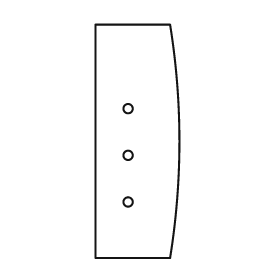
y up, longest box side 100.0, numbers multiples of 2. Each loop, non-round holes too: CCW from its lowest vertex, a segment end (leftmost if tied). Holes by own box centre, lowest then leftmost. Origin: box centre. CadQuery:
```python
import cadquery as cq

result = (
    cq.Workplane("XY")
    .moveTo(-18.0, -50.0)
    .lineTo(14.0, -50.0)
    .threePointArc((18.0, 0.0), (14.0, 50.0))
    .lineTo(-18.0, 50.0)
    .close()
    .moveTo(-4.0, -26.0)
    .circle(2.0)
    .moveTo(-4.0, -6.0)
    .circle(2.0)
    .moveTo(-4.0, 14.0)
    .circle(2.0)
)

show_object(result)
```